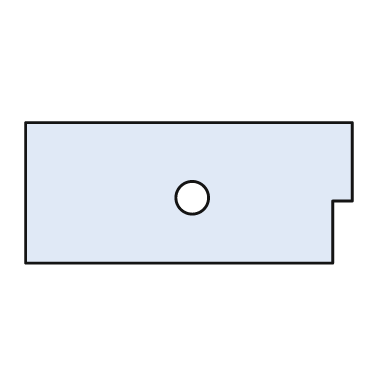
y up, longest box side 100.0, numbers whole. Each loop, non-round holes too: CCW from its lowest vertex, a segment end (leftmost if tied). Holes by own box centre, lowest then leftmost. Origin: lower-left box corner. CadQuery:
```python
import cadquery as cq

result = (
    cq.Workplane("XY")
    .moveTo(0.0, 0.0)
    .lineTo(94.0, 0.0)
    .lineTo(94.0, 19.0)
    .lineTo(100.0, 19.0)
    .lineTo(100.0, 43.0)
    .lineTo(0.0, 43.0)
    .close()
    .moveTo(51.0, 20.0)
    .circle(5.0)
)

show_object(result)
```